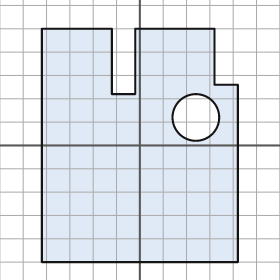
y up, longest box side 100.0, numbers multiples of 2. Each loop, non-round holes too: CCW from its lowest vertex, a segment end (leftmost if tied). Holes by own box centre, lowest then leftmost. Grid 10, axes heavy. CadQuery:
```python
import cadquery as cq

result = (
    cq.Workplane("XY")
    .moveTo(-42.0, -50.0)
    .lineTo(42.0, -50.0)
    .lineTo(42.0, 26.0)
    .lineTo(32.0, 26.0)
    .lineTo(32.0, 50.0)
    .lineTo(-2.0, 50.0)
    .lineTo(-2.0, 22.0)
    .lineTo(-12.0, 22.0)
    .lineTo(-12.0, 50.0)
    .lineTo(-42.0, 50.0)
    .close()
    .moveTo(24.0, 12.0)
    .circle(10.0)
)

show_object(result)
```